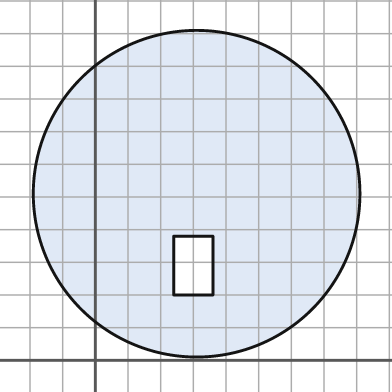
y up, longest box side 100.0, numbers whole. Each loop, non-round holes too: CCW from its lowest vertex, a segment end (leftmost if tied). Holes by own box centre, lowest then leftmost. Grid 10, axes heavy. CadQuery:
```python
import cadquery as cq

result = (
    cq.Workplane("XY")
    .moveTo(31.0, 51.0)
    .circle(50.0)
    .moveTo(24.0, 20.0)
    .lineTo(36.0, 20.0)
    .lineTo(36.0, 38.0)
    .lineTo(24.0, 38.0)
    .close()
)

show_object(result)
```